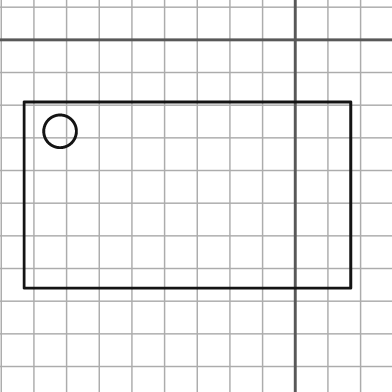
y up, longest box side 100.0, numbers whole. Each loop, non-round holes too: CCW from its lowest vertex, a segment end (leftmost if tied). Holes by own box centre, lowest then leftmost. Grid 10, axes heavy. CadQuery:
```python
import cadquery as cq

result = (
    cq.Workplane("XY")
    .moveTo(-83.0, -76.0)
    .lineTo(17.0, -76.0)
    .lineTo(17.0, -19.0)
    .lineTo(-83.0, -19.0)
    .close()
    .moveTo(-72.0, -28.0)
    .circle(5.0)
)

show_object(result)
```